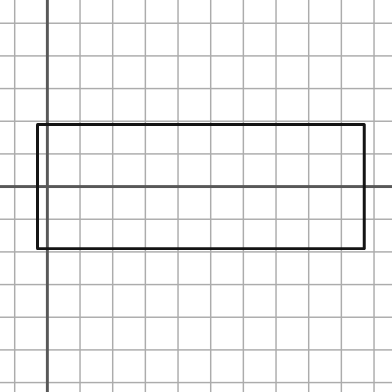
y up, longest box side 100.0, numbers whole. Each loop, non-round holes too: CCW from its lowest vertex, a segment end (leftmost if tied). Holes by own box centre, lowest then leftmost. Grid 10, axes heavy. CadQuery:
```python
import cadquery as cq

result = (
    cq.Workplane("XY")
    .moveTo(-3.0, -19.0)
    .lineTo(97.0, -19.0)
    .lineTo(97.0, 19.0)
    .lineTo(-3.0, 19.0)
    .close()
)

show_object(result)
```